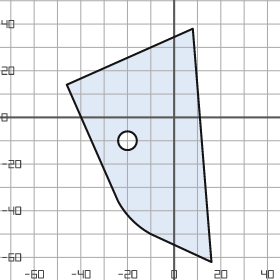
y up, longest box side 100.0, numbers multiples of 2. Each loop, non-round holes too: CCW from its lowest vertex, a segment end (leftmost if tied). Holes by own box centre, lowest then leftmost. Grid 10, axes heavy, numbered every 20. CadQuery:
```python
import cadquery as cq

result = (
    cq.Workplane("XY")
    .moveTo(16.0, -62.0)
    .lineTo(8.0, 38.0)
    .lineTo(-46.0, 14.0)
    .lineTo(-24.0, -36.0)
    .threePointArc((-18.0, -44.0), (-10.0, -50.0))
    .close()
    .moveTo(-20.0, -10.0)
    .circle(4.0)
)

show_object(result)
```